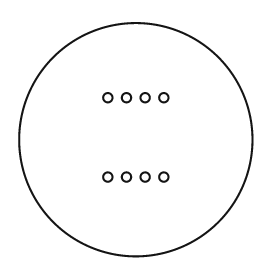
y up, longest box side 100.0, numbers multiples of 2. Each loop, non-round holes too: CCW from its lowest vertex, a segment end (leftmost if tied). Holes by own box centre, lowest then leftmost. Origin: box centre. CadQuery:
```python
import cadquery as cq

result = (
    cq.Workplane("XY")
    .moveTo(0.0, 0.0)
    .circle(50.0)
    .moveTo(-12.0, -16.0)
    .circle(2.0)
    .moveTo(-4.0, -16.0)
    .circle(2.0)
    .moveTo(4.0, -16.0)
    .circle(2.0)
    .moveTo(12.0, -16.0)
    .circle(2.0)
    .moveTo(-12.0, 18.0)
    .circle(2.0)
    .moveTo(-4.0, 18.0)
    .circle(2.0)
    .moveTo(4.0, 18.0)
    .circle(2.0)
    .moveTo(12.0, 18.0)
    .circle(2.0)
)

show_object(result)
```